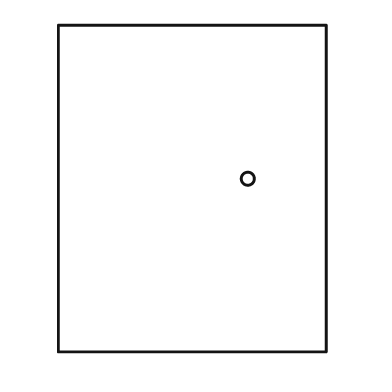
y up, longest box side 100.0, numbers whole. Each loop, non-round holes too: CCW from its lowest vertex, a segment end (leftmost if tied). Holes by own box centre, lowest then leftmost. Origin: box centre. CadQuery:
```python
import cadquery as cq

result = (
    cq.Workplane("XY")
    .moveTo(-41.0, -50.0)
    .lineTo(41.0, -50.0)
    .lineTo(41.0, 50.0)
    .lineTo(-41.0, 50.0)
    .close()
    .moveTo(17.0, 3.0)
    .circle(2.0)
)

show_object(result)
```